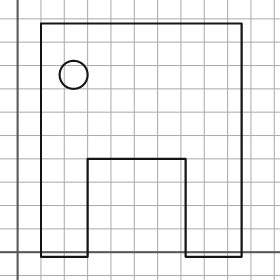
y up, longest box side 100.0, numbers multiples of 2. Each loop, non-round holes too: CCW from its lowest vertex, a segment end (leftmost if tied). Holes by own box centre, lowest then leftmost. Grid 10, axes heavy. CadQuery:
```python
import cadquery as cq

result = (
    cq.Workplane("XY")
    .moveTo(10.0, -2.0)
    .lineTo(30.0, -2.0)
    .lineTo(30.0, 40.0)
    .lineTo(72.0, 40.0)
    .lineTo(72.0, -2.0)
    .lineTo(96.0, -2.0)
    .lineTo(96.0, 98.0)
    .lineTo(10.0, 98.0)
    .close()
    .moveTo(24.0, 76.0)
    .circle(6.0)
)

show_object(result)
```